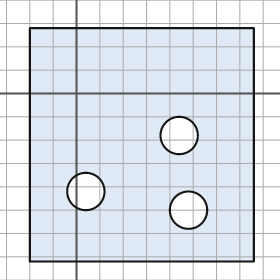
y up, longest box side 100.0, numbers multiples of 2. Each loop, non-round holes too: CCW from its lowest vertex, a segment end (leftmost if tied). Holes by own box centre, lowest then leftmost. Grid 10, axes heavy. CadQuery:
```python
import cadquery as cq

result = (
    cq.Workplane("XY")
    .moveTo(-20.0, -72.0)
    .lineTo(76.0, -72.0)
    .lineTo(76.0, 28.0)
    .lineTo(-20.0, 28.0)
    .close()
    .moveTo(48.0, -50.0)
    .circle(8.0)
    .moveTo(4.0, -42.0)
    .circle(8.0)
    .moveTo(44.0, -18.0)
    .circle(8.0)
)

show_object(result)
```